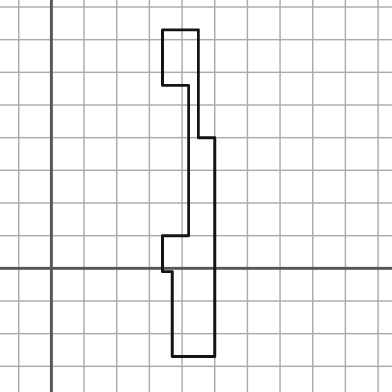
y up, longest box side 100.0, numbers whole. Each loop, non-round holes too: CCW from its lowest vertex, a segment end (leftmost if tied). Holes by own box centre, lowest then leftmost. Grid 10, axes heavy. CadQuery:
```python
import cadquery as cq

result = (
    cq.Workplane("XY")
    .moveTo(37.0, -27.0)
    .lineTo(50.0, -27.0)
    .lineTo(50.0, 40.0)
    .lineTo(45.0, 40.0)
    .lineTo(45.0, 73.0)
    .lineTo(34.0, 73.0)
    .lineTo(34.0, 56.0)
    .lineTo(42.0, 56.0)
    .lineTo(42.0, 10.0)
    .lineTo(34.0, 10.0)
    .lineTo(34.0, -1.0)
    .lineTo(37.0, -1.0)
    .close()
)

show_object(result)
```